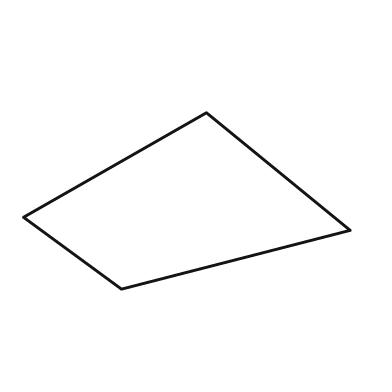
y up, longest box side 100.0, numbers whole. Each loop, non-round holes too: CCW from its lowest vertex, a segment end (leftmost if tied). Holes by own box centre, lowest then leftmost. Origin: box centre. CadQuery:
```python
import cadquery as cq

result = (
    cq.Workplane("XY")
    .moveTo(-20.0, -27.0)
    .lineTo(50.0, -9.0)
    .lineTo(6.0, 27.0)
    .lineTo(-50.0, -5.0)
    .close()
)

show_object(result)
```